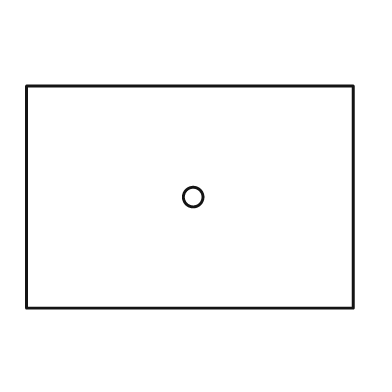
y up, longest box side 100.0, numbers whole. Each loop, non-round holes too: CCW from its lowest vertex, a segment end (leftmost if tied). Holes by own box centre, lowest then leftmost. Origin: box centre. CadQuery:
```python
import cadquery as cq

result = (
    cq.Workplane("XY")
    .moveTo(-50.0, -34.0)
    .lineTo(50.0, -34.0)
    .lineTo(50.0, 34.0)
    .lineTo(-50.0, 34.0)
    .close()
    .moveTo(1.0, 0.0)
    .circle(3.0)
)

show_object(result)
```